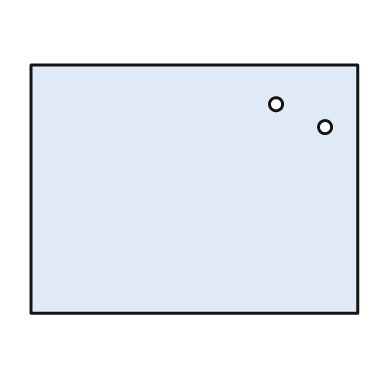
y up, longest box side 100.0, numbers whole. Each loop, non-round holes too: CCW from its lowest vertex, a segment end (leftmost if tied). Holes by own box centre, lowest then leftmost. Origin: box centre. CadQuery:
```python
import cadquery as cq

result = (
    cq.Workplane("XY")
    .moveTo(-50.0, -38.0)
    .lineTo(50.0, -38.0)
    .lineTo(50.0, 38.0)
    .lineTo(-50.0, 38.0)
    .close()
    .moveTo(40.0, 19.0)
    .circle(2.0)
    .moveTo(25.0, 26.0)
    .circle(2.0)
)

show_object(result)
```